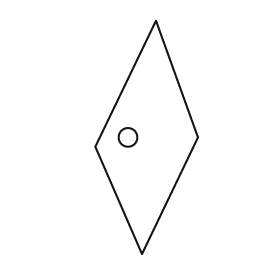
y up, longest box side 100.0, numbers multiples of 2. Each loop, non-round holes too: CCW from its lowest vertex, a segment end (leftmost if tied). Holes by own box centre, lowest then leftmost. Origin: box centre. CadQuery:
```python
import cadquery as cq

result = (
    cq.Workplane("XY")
    .moveTo(-2.0, -50.0)
    .lineTo(22.0, 0.0)
    .lineTo(4.0, 50.0)
    .lineTo(-22.0, -4.0)
    .close()
    .moveTo(-8.0, 0.0)
    .circle(4.0)
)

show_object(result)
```